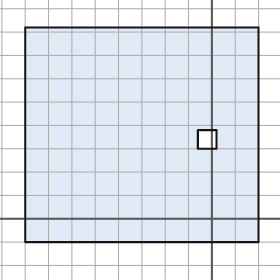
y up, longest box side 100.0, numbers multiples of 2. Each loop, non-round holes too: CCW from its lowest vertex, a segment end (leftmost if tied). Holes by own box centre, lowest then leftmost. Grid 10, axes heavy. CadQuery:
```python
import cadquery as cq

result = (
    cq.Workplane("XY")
    .moveTo(-80.0, -10.0)
    .lineTo(20.0, -10.0)
    .lineTo(20.0, 82.0)
    .lineTo(-80.0, 82.0)
    .close()
    .moveTo(-6.0, 30.0)
    .lineTo(2.0, 30.0)
    .lineTo(2.0, 38.0)
    .lineTo(-6.0, 38.0)
    .close()
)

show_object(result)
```